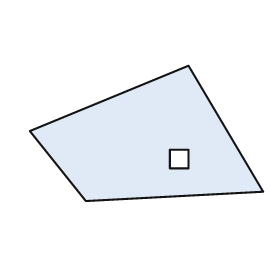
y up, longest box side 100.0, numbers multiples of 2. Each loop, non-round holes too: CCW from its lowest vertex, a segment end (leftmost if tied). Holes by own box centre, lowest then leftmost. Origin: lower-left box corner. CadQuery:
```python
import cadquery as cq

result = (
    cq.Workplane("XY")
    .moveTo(24.0, 0.0)
    .lineTo(100.0, 4.0)
    .lineTo(68.0, 58.0)
    .lineTo(0.0, 30.0)
    .close()
    .moveTo(60.0, 14.0)
    .lineTo(68.0, 14.0)
    .lineTo(68.0, 22.0)
    .lineTo(60.0, 22.0)
    .close()
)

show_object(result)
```